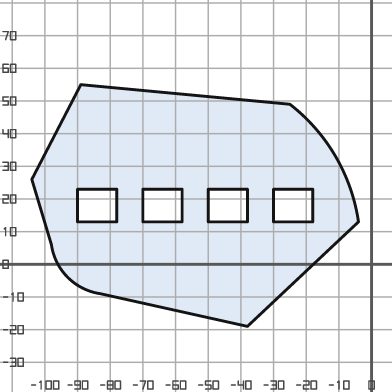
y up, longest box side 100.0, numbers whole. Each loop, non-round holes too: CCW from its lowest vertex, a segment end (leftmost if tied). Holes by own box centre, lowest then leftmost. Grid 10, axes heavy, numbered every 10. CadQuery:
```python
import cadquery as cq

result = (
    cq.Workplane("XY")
    .moveTo(-38.0, -19.0)
    .lineTo(-4.0, 13.0)
    .threePointArc((-11.0, 33.0), (-25.0, 49.0))
    .lineTo(-89.0, 55.0)
    .lineTo(-104.0, 26.0)
    .lineTo(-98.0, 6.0)
    .threePointArc((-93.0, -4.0), (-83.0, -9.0))
    .close()
    .moveTo(-90.0, 13.0)
    .lineTo(-78.0, 13.0)
    .lineTo(-78.0, 23.0)
    .lineTo(-90.0, 23.0)
    .close()
    .moveTo(-70.0, 13.0)
    .lineTo(-58.0, 13.0)
    .lineTo(-58.0, 23.0)
    .lineTo(-70.0, 23.0)
    .close()
    .moveTo(-50.0, 13.0)
    .lineTo(-38.0, 13.0)
    .lineTo(-38.0, 23.0)
    .lineTo(-50.0, 23.0)
    .close()
    .moveTo(-30.0, 13.0)
    .lineTo(-18.0, 13.0)
    .lineTo(-18.0, 23.0)
    .lineTo(-30.0, 23.0)
    .close()
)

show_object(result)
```